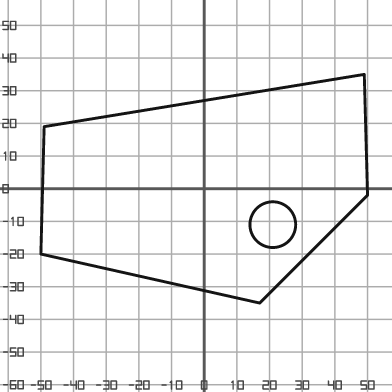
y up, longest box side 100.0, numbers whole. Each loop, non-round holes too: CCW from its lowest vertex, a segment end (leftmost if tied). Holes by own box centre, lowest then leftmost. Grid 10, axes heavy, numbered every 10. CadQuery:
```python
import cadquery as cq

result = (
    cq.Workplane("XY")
    .moveTo(17.0, -35.0)
    .lineTo(50.0, -2.0)
    .lineTo(49.0, 35.0)
    .lineTo(-49.0, 19.0)
    .lineTo(-50.0, -20.0)
    .close()
    .moveTo(21.0, -11.0)
    .circle(7.0)
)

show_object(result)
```